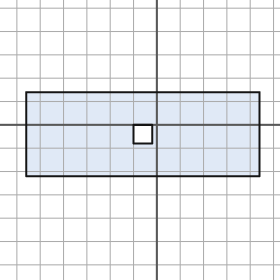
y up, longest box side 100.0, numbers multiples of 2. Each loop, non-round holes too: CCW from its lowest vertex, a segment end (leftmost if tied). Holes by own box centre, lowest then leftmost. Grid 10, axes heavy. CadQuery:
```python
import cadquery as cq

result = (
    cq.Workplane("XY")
    .moveTo(-56.0, -22.0)
    .lineTo(44.0, -22.0)
    .lineTo(44.0, 14.0)
    .lineTo(-56.0, 14.0)
    .close()
    .moveTo(-10.0, -8.0)
    .lineTo(-2.0, -8.0)
    .lineTo(-2.0, 0.0)
    .lineTo(-10.0, 0.0)
    .close()
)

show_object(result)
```